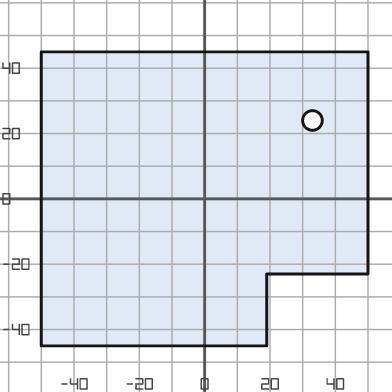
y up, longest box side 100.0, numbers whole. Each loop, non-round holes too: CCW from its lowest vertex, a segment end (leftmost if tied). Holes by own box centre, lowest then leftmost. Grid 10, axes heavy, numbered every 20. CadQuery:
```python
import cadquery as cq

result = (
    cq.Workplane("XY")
    .moveTo(-50.0, -45.0)
    .lineTo(19.0, -45.0)
    .lineTo(19.0, -23.0)
    .lineTo(50.0, -23.0)
    .lineTo(50.0, 45.0)
    .lineTo(-50.0, 45.0)
    .close()
    .moveTo(33.0, 24.0)
    .circle(3.0)
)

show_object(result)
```